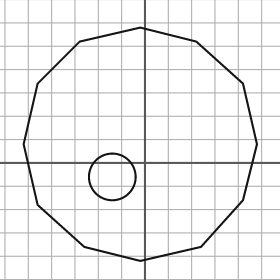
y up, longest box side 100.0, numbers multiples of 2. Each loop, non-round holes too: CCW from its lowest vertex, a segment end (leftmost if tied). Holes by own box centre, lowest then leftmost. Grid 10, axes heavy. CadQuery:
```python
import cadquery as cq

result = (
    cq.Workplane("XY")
    .moveTo(-2.0, -42.0)
    .lineTo(24.0, -36.0)
    .lineTo(42.0, -16.0)
    .lineTo(48.0, 8.0)
    .lineTo(42.0, 34.0)
    .lineTo(22.0, 52.0)
    .lineTo(-2.0, 58.0)
    .lineTo(-28.0, 52.0)
    .lineTo(-46.0, 34.0)
    .lineTo(-52.0, 8.0)
    .lineTo(-46.0, -18.0)
    .lineTo(-26.0, -36.0)
    .close()
    .moveTo(-14.0, -6.0)
    .circle(10.0)
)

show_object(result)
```